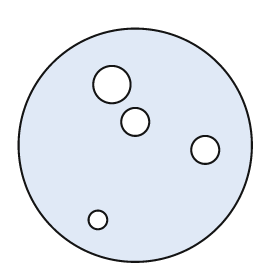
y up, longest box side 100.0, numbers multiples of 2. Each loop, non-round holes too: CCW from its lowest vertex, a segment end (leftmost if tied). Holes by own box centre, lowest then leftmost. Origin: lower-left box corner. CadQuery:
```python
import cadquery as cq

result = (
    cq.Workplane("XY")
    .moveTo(50.0, 50.0)
    .circle(50.0)
    .moveTo(34.0, 18.0)
    .circle(4.0)
    .moveTo(80.0, 48.0)
    .circle(6.0)
    .moveTo(50.0, 60.0)
    .circle(6.0)
    .moveTo(40.0, 76.0)
    .circle(8.0)
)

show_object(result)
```